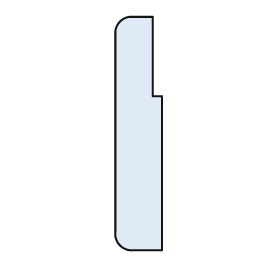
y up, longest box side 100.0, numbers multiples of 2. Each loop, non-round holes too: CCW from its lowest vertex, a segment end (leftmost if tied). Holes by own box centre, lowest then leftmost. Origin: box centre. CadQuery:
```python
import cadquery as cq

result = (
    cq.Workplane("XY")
    .moveTo(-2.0, -50.0)
    .lineTo(10.0, -50.0)
    .lineTo(10.0, 16.0)
    .lineTo(6.0, 16.0)
    .lineTo(6.0, 50.0)
    .lineTo(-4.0, 50.0)
    .threePointArc((-8.0, 48.0), (-10.0, 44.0))
    .lineTo(-10.0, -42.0)
    .threePointArc((-8.0, -48.0), (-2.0, -50.0))
    .close()
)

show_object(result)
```